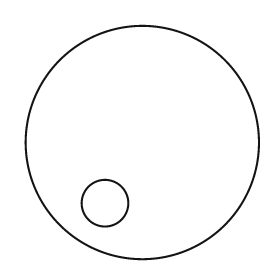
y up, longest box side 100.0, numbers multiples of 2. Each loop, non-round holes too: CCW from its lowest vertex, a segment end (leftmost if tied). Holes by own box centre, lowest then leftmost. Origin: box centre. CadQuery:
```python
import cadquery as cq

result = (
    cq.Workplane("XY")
    .moveTo(0.0, 0.0)
    .circle(50.0)
    .moveTo(-16.0, -26.0)
    .circle(10.0)
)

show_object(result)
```